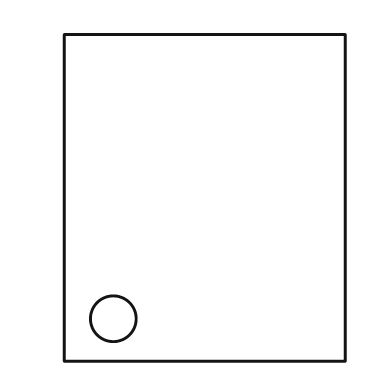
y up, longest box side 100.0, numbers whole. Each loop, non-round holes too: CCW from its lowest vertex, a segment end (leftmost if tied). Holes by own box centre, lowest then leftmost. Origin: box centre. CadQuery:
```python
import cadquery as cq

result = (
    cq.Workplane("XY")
    .moveTo(-43.0, -50.0)
    .lineTo(43.0, -50.0)
    .lineTo(43.0, 50.0)
    .lineTo(-43.0, 50.0)
    .close()
    .moveTo(-28.0, -37.0)
    .circle(7.0)
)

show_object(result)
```